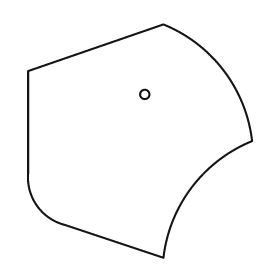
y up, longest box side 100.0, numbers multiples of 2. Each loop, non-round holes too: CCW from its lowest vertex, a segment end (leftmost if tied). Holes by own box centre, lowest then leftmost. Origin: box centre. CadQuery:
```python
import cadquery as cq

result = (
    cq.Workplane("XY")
    .moveTo(10.0, -50.0)
    .threePointArc((22.0, -20.0), (48.0, 0.0))
    .threePointArc((36.0, 30.0), (10.0, 50.0))
    .lineTo(-48.0, 30.0)
    .lineTo(-48.0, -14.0)
    .threePointArc((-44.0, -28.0), (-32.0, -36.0))
    .close()
    .moveTo(2.0, 20.0)
    .circle(2.0)
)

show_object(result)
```